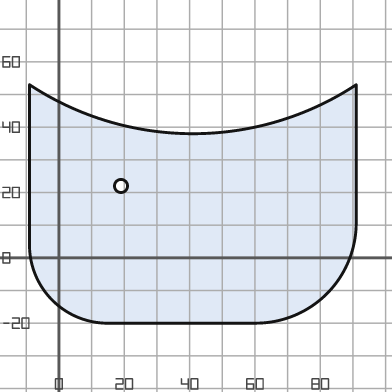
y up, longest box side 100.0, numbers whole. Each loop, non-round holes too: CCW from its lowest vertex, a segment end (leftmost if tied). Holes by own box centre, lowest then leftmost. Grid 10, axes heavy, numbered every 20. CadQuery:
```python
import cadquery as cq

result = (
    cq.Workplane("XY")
    .moveTo(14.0, -20.0)
    .lineTo(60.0, -20.0)
    .threePointArc((82.0, -11.0), (91.0, 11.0))
    .lineTo(91.0, 53.0)
    .threePointArc((41.0, 38.0), (-9.0, 53.0))
    .lineTo(-9.0, 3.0)
    .threePointArc((-2.0, -13.0), (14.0, -20.0))
    .close()
    .moveTo(19.0, 22.0)
    .circle(2.0)
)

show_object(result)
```